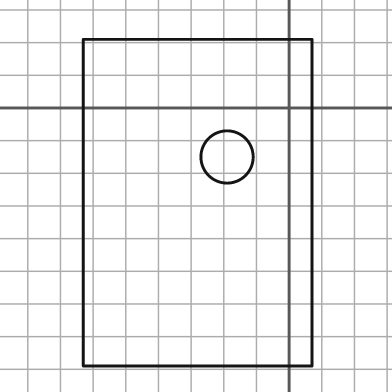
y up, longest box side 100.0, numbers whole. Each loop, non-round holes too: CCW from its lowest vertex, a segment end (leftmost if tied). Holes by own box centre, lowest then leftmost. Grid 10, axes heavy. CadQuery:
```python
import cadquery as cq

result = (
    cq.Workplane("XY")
    .moveTo(-63.0, -79.0)
    .lineTo(7.0, -79.0)
    .lineTo(7.0, 21.0)
    .lineTo(-63.0, 21.0)
    .close()
    .moveTo(-19.0, -15.0)
    .circle(8.0)
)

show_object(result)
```